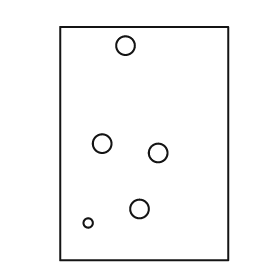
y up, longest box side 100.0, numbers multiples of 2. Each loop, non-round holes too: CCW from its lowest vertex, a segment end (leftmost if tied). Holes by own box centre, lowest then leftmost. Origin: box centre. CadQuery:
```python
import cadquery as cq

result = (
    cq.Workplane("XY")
    .moveTo(-36.0, -50.0)
    .lineTo(36.0, -50.0)
    .lineTo(36.0, 50.0)
    .lineTo(-36.0, 50.0)
    .close()
    .moveTo(-24.0, -34.0)
    .circle(2.0)
    .moveTo(-2.0, -28.0)
    .circle(4.0)
    .moveTo(6.0, -4.0)
    .circle(4.0)
    .moveTo(-18.0, 0.0)
    .circle(4.0)
    .moveTo(-8.0, 42.0)
    .circle(4.0)
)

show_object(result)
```